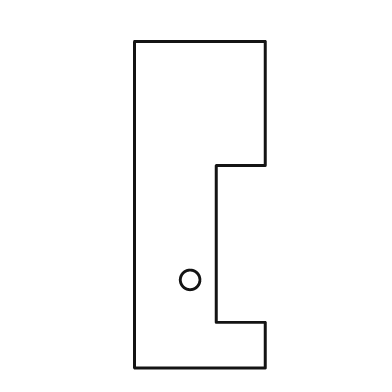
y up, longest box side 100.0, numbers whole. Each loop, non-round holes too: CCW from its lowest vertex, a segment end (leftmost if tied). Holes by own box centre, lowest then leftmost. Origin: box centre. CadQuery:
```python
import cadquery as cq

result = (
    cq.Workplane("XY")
    .moveTo(-20.0, -50.0)
    .lineTo(20.0, -50.0)
    .lineTo(20.0, -36.0)
    .lineTo(5.0, -36.0)
    .lineTo(5.0, 12.0)
    .lineTo(20.0, 12.0)
    .lineTo(20.0, 50.0)
    .lineTo(-20.0, 50.0)
    .close()
    .moveTo(-3.0, -23.0)
    .circle(3.0)
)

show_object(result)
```